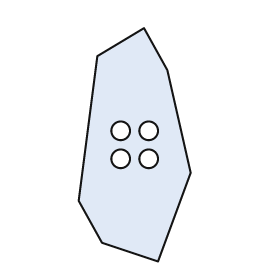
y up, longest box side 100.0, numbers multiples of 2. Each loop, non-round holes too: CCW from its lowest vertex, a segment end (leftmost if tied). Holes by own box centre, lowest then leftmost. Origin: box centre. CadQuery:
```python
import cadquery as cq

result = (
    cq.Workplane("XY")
    .moveTo(10.0, -50.0)
    .lineTo(24.0, -12.0)
    .lineTo(14.0, 32.0)
    .lineTo(4.0, 50.0)
    .lineTo(-16.0, 38.0)
    .lineTo(-24.0, -24.0)
    .lineTo(-14.0, -42.0)
    .close()
    .moveTo(-6.0, -6.0)
    .circle(4.0)
    .moveTo(6.0, -6.0)
    .circle(4.0)
    .moveTo(-6.0, 6.0)
    .circle(4.0)
    .moveTo(6.0, 6.0)
    .circle(4.0)
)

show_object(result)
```